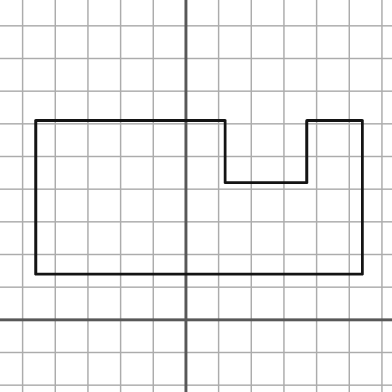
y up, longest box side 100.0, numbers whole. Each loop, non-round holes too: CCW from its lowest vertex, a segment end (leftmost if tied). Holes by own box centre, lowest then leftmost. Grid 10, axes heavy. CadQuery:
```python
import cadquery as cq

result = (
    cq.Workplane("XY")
    .moveTo(-46.0, 14.0)
    .lineTo(54.0, 14.0)
    .lineTo(54.0, 61.0)
    .lineTo(37.0, 61.0)
    .lineTo(37.0, 42.0)
    .lineTo(12.0, 42.0)
    .lineTo(12.0, 61.0)
    .lineTo(-46.0, 61.0)
    .close()
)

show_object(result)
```